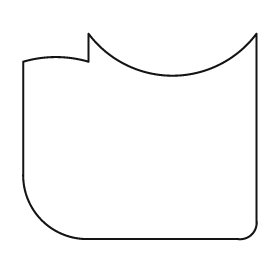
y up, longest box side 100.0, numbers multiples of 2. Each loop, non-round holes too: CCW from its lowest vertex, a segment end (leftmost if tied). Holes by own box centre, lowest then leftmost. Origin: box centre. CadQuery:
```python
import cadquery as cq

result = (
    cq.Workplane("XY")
    .moveTo(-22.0, -44.0)
    .lineTo(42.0, -44.0)
    .threePointArc((48.0, -42.0), (50.0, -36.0))
    .lineTo(50.0, 44.0)
    .threePointArc((14.0, 26.0), (-22.0, 44.0))
    .lineTo(-22.0, 32.0)
    .threePointArc((-36.0, 34.0), (-50.0, 32.0))
    .lineTo(-50.0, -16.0)
    .threePointArc((-42.0, -36.0), (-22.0, -44.0))
    .close()
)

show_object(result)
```